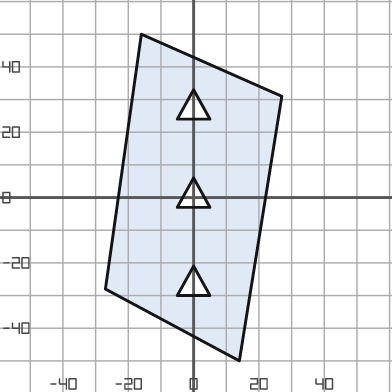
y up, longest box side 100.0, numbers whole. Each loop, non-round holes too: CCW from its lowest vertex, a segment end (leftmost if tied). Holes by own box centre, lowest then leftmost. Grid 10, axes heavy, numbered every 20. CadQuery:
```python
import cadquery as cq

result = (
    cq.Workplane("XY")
    .moveTo(14.0, -50.0)
    .lineTo(27.0, 31.0)
    .lineTo(-16.0, 50.0)
    .lineTo(-27.0, -28.0)
    .close()
    .moveTo(-5.0, -30.0)
    .lineTo(5.0, -30.0)
    .lineTo(0.0, -21.0)
    .close()
    .moveTo(-5.0, -3.0)
    .lineTo(5.0, -3.0)
    .lineTo(0.0, 6.0)
    .close()
    .moveTo(-5.0, 24.0)
    .lineTo(5.0, 24.0)
    .lineTo(0.0, 33.0)
    .close()
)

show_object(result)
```